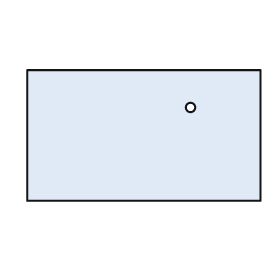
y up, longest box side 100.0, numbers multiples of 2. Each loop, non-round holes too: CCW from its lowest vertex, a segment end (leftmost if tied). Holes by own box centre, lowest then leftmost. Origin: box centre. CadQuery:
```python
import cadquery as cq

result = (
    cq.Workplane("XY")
    .moveTo(-50.0, -28.0)
    .lineTo(50.0, -28.0)
    .lineTo(50.0, 28.0)
    .lineTo(-50.0, 28.0)
    .close()
    .moveTo(20.0, 12.0)
    .circle(2.0)
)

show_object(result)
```